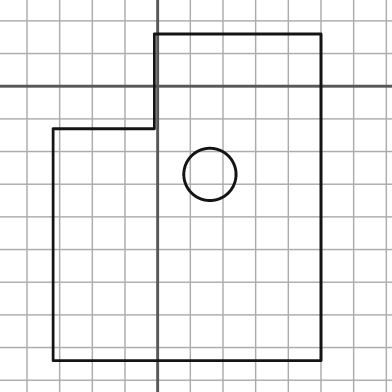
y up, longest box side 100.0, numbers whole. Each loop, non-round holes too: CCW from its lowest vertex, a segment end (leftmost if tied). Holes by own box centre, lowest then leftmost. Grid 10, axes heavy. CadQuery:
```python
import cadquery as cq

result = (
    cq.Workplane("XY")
    .moveTo(-32.0, -84.0)
    .lineTo(50.0, -84.0)
    .lineTo(50.0, 16.0)
    .lineTo(-1.0, 16.0)
    .lineTo(-1.0, -13.0)
    .lineTo(-32.0, -13.0)
    .close()
    .moveTo(16.0, -27.0)
    .circle(8.0)
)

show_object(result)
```